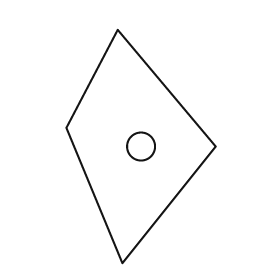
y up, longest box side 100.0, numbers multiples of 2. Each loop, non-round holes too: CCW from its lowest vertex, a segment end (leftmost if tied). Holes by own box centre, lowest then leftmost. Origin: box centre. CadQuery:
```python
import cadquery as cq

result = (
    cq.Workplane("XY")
    .moveTo(-8.0, -50.0)
    .lineTo(32.0, 0.0)
    .lineTo(-10.0, 50.0)
    .lineTo(-32.0, 8.0)
    .close()
    .moveTo(0.0, 0.0)
    .circle(6.0)
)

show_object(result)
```